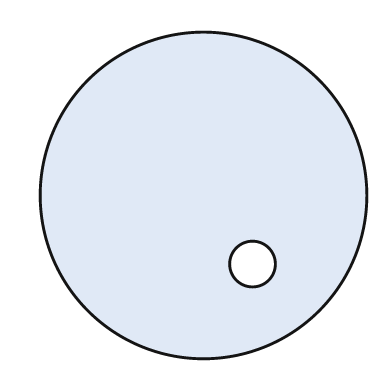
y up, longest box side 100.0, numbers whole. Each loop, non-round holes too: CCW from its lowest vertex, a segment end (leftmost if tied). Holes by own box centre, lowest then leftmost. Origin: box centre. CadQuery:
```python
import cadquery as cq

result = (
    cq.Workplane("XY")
    .moveTo(0.0, 0.0)
    .circle(50.0)
    .moveTo(15.0, -21.0)
    .circle(7.0)
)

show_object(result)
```